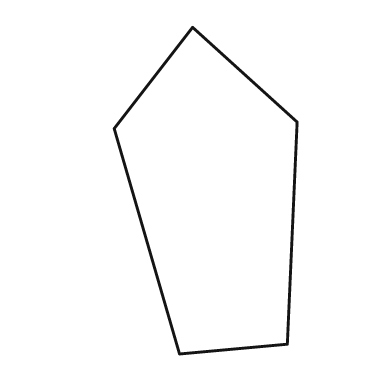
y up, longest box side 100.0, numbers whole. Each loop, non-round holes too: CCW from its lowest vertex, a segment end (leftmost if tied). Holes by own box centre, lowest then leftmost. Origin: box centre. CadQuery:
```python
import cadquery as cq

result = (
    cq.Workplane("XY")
    .moveTo(-8.0, -50.0)
    .lineTo(25.0, -47.0)
    .lineTo(28.0, 21.0)
    .lineTo(-4.0, 50.0)
    .lineTo(-28.0, 19.0)
    .close()
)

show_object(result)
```